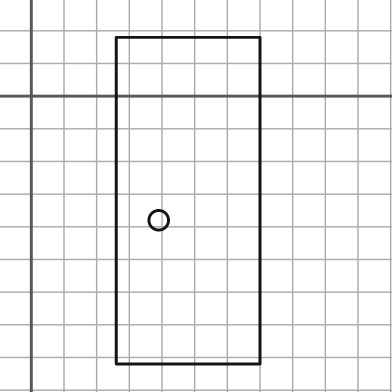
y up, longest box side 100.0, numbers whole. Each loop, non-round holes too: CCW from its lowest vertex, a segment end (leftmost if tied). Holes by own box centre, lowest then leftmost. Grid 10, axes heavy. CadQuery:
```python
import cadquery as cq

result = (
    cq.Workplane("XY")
    .moveTo(26.0, -82.0)
    .lineTo(70.0, -82.0)
    .lineTo(70.0, 18.0)
    .lineTo(26.0, 18.0)
    .close()
    .moveTo(39.0, -38.0)
    .circle(3.0)
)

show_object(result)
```